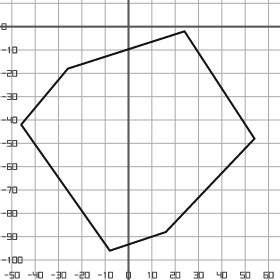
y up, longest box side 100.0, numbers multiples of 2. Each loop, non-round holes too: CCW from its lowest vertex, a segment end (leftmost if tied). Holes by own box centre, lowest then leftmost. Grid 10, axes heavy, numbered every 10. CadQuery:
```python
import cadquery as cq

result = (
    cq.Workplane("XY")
    .moveTo(-8.0, -96.0)
    .lineTo(16.0, -88.0)
    .lineTo(54.0, -48.0)
    .lineTo(24.0, -2.0)
    .lineTo(-26.0, -18.0)
    .lineTo(-46.0, -42.0)
    .close()
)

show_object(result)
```